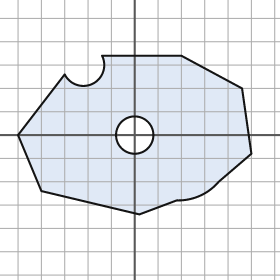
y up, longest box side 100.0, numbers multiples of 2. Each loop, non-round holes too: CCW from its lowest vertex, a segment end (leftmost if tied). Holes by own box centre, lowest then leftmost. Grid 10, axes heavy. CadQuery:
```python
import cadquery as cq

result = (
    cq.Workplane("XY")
    .moveTo(2.0, -34.0)
    .lineTo(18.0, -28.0)
    .threePointArc((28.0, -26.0), (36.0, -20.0))
    .lineTo(50.0, -8.0)
    .lineTo(46.0, 20.0)
    .lineTo(20.0, 34.0)
    .lineTo(-14.0, 34.0)
    .threePointArc((-18.0, 22.0), (-30.0, 26.0))
    .lineTo(-50.0, 0.0)
    .lineTo(-40.0, -24.0)
    .close()
    .moveTo(0.0, 0.0)
    .circle(8.0)
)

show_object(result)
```